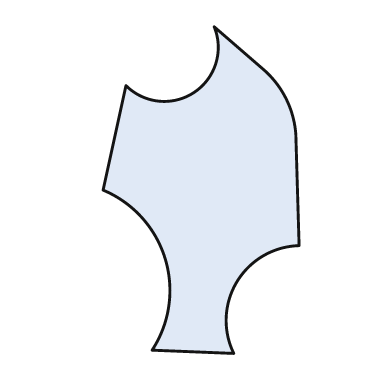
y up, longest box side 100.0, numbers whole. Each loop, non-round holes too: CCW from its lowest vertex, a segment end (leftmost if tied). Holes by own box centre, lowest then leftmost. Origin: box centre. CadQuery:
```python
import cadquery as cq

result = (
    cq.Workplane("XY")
    .moveTo(10.0, -50.0)
    .threePointArc((11.0, -28.0), (30.0, -17.0))
    .lineTo(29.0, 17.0)
    .threePointArc((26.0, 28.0), (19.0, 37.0))
    .lineTo(4.0, 50.0)
    .threePointArc((-2.0, 30.0), (-23.0, 32.0))
    .lineTo(-30.0, 0.0)
    .threePointArc((-11.0, -21.0), (-15.0, -49.0))
    .close()
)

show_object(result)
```